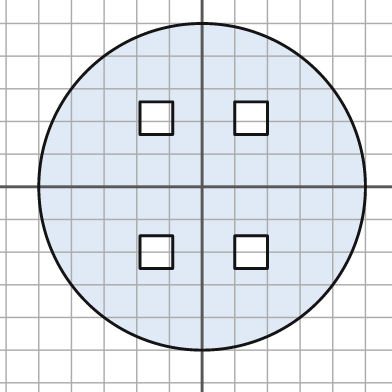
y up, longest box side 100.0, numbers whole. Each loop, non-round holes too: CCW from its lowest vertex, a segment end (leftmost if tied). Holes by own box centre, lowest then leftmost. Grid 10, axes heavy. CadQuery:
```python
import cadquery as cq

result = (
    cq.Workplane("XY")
    .moveTo(0.0, 0.0)
    .circle(50.0)
    .moveTo(-19.0, -25.0)
    .lineTo(-9.0, -25.0)
    .lineTo(-9.0, -15.0)
    .lineTo(-19.0, -15.0)
    .close()
    .moveTo(10.0, -25.0)
    .lineTo(20.0, -25.0)
    .lineTo(20.0, -15.0)
    .lineTo(10.0, -15.0)
    .close()
    .moveTo(-19.0, 16.0)
    .lineTo(-9.0, 16.0)
    .lineTo(-9.0, 26.0)
    .lineTo(-19.0, 26.0)
    .close()
    .moveTo(10.0, 16.0)
    .lineTo(20.0, 16.0)
    .lineTo(20.0, 26.0)
    .lineTo(10.0, 26.0)
    .close()
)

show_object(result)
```